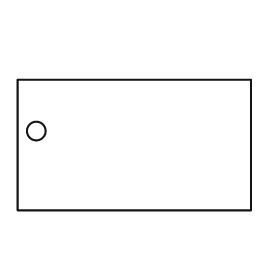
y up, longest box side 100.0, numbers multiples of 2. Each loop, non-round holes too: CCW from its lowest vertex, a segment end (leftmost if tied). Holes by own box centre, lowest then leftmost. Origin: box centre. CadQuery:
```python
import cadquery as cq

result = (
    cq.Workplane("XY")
    .moveTo(-50.0, -28.0)
    .lineTo(50.0, -28.0)
    .lineTo(50.0, 28.0)
    .lineTo(-50.0, 28.0)
    .close()
    .moveTo(-42.0, 6.0)
    .circle(4.0)
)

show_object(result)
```